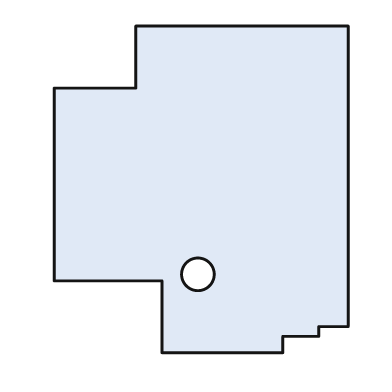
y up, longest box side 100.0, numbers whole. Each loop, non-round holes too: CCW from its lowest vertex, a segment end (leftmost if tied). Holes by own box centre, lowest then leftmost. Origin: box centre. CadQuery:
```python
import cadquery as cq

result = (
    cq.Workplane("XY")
    .moveTo(-12.0, -50.0)
    .lineTo(25.0, -50.0)
    .lineTo(25.0, -45.0)
    .lineTo(36.0, -45.0)
    .lineTo(36.0, -42.0)
    .lineTo(45.0, -42.0)
    .lineTo(45.0, 50.0)
    .lineTo(-20.0, 50.0)
    .lineTo(-20.0, 31.0)
    .lineTo(-45.0, 31.0)
    .lineTo(-45.0, -28.0)
    .lineTo(-12.0, -28.0)
    .close()
    .moveTo(-1.0, -26.0)
    .circle(5.0)
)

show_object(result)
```